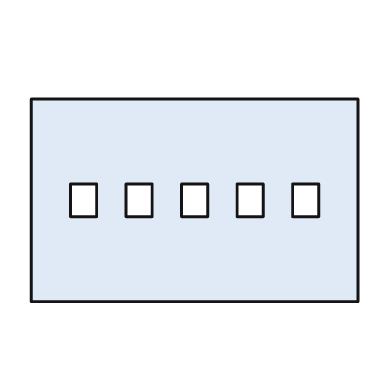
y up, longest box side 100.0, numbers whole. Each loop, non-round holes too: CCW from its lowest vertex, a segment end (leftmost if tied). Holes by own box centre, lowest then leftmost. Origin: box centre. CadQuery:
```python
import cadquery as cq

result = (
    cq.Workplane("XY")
    .moveTo(-50.0, -31.0)
    .lineTo(50.0, -31.0)
    .lineTo(50.0, 31.0)
    .lineTo(-50.0, 31.0)
    .close()
    .moveTo(-38.0, -5.0)
    .lineTo(-30.0, -5.0)
    .lineTo(-30.0, 5.0)
    .lineTo(-38.0, 5.0)
    .close()
    .moveTo(-21.0, -5.0)
    .lineTo(-13.0, -5.0)
    .lineTo(-13.0, 5.0)
    .lineTo(-21.0, 5.0)
    .close()
    .moveTo(-4.0, -5.0)
    .lineTo(4.0, -5.0)
    .lineTo(4.0, 5.0)
    .lineTo(-4.0, 5.0)
    .close()
    .moveTo(13.0, -5.0)
    .lineTo(21.0, -5.0)
    .lineTo(21.0, 5.0)
    .lineTo(13.0, 5.0)
    .close()
    .moveTo(30.0, -5.0)
    .lineTo(38.0, -5.0)
    .lineTo(38.0, 5.0)
    .lineTo(30.0, 5.0)
    .close()
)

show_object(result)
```